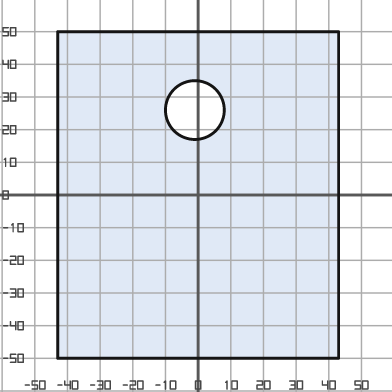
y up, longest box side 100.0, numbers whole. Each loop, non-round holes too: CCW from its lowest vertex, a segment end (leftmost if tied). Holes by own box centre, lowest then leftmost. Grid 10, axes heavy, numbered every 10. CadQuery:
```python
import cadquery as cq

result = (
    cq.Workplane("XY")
    .moveTo(-43.0, -50.0)
    .lineTo(43.0, -50.0)
    .lineTo(43.0, 50.0)
    .lineTo(-43.0, 50.0)
    .close()
    .moveTo(-1.0, 26.0)
    .circle(9.0)
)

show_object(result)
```